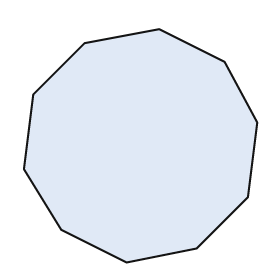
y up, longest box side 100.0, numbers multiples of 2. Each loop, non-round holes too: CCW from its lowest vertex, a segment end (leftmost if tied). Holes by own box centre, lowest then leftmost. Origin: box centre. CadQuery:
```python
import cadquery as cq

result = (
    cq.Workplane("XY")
    .moveTo(-6.0, -50.0)
    .lineTo(24.0, -44.0)
    .lineTo(46.0, -22.0)
    .lineTo(50.0, 10.0)
    .lineTo(36.0, 36.0)
    .lineTo(8.0, 50.0)
    .lineTo(-24.0, 44.0)
    .lineTo(-46.0, 22.0)
    .lineTo(-50.0, -10.0)
    .lineTo(-34.0, -36.0)
    .close()
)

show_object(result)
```